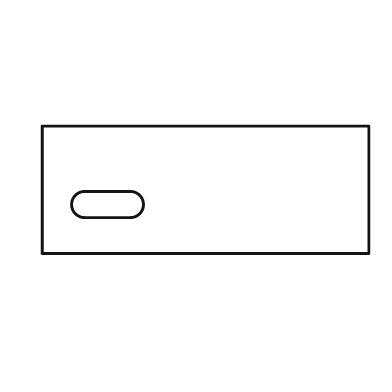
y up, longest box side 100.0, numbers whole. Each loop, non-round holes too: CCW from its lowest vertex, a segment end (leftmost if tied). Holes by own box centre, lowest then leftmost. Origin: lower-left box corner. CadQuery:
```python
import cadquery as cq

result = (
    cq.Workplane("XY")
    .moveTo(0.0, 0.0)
    .lineTo(100.0, 0.0)
    .lineTo(100.0, 39.0)
    .lineTo(0.0, 39.0)
    .close()
    .moveTo(13.0, 11.0)
    .lineTo(27.0, 11.0)
    .threePointArc((31.0, 15.0), (27.0, 19.0))
    .lineTo(13.0, 19.0)
    .threePointArc((9.0, 15.0), (13.0, 11.0))
    .close()
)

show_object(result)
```